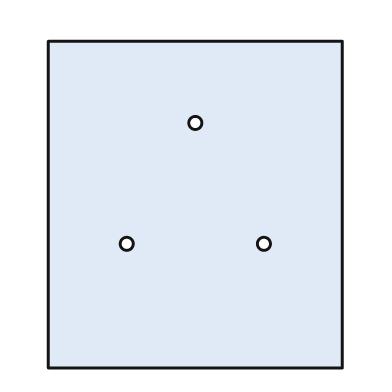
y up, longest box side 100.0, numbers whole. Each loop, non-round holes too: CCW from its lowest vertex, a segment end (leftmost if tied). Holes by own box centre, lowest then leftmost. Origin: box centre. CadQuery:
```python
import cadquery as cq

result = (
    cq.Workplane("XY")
    .moveTo(-45.0, -50.0)
    .lineTo(45.0, -50.0)
    .lineTo(45.0, 50.0)
    .lineTo(-45.0, 50.0)
    .close()
    .moveTo(-21.0, -12.0)
    .circle(2.0)
    .moveTo(21.0, -12.0)
    .circle(2.0)
    .moveTo(0.0, 25.0)
    .circle(2.0)
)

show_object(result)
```